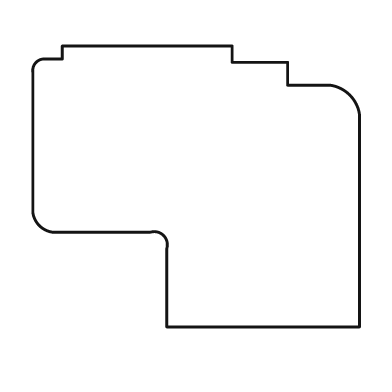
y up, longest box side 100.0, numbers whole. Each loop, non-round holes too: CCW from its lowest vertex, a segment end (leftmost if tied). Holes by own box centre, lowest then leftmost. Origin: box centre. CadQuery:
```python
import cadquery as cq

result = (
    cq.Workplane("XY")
    .moveTo(-9.0, -43.0)
    .lineTo(50.0, -43.0)
    .lineTo(50.0, 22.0)
    .threePointArc((47.0, 28.0), (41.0, 31.0))
    .lineTo(28.0, 31.0)
    .lineTo(28.0, 38.0)
    .lineTo(11.0, 38.0)
    .lineTo(11.0, 43.0)
    .lineTo(-41.0, 43.0)
    .lineTo(-41.0, 39.0)
    .lineTo(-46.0, 39.0)
    .threePointArc((-49.0, 38.0), (-50.0, 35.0))
    .lineTo(-50.0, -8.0)
    .threePointArc((-48.0, -12.0), (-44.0, -14.0))
    .lineTo(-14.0, -14.0)
    .threePointArc((-10.0, -15.0), (-9.0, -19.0))
    .close()
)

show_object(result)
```